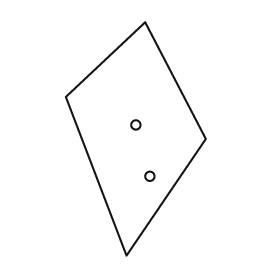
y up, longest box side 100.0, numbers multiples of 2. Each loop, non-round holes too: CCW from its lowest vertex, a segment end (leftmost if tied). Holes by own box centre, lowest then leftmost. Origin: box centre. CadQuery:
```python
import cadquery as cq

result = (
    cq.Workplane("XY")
    .moveTo(-4.0, -50.0)
    .lineTo(30.0, 0.0)
    .lineTo(4.0, 50.0)
    .lineTo(-30.0, 18.0)
    .close()
    .moveTo(6.0, -16.0)
    .circle(2.0)
    .moveTo(0.0, 6.0)
    .circle(2.0)
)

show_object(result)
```